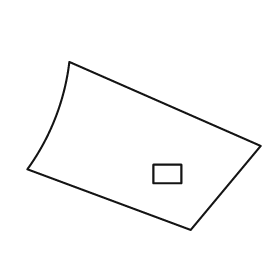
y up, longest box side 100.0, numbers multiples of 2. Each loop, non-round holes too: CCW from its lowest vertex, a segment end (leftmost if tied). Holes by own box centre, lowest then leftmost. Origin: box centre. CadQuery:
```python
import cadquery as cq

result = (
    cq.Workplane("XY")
    .moveTo(20.0, -36.0)
    .lineTo(50.0, 0.0)
    .lineTo(-32.0, 36.0)
    .threePointArc((-38.0, 12.0), (-50.0, -10.0))
    .close()
    .moveTo(4.0, -16.0)
    .lineTo(16.0, -16.0)
    .lineTo(16.0, -8.0)
    .lineTo(4.0, -8.0)
    .close()
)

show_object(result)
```